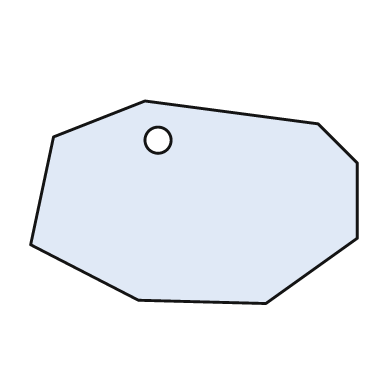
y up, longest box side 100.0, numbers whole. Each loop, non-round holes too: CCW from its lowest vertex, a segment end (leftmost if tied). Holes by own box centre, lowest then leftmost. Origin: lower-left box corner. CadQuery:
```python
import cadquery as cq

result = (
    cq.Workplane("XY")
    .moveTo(72.0, 0.0)
    .lineTo(100.0, 20.0)
    .lineTo(100.0, 43.0)
    .lineTo(88.0, 55.0)
    .lineTo(35.0, 62.0)
    .lineTo(7.0, 51.0)
    .lineTo(0.0, 18.0)
    .lineTo(33.0, 1.0)
    .close()
    .moveTo(39.0, 50.0)
    .circle(4.0)
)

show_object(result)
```